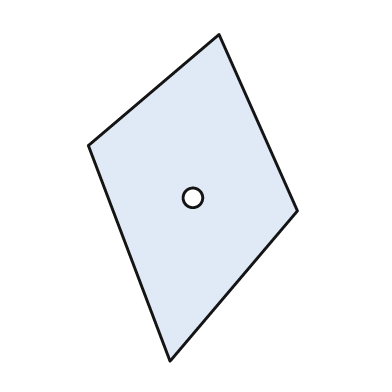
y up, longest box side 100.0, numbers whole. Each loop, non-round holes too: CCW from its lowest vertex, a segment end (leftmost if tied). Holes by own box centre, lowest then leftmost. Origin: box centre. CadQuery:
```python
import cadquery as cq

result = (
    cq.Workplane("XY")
    .moveTo(-7.0, -50.0)
    .lineTo(32.0, -4.0)
    .lineTo(8.0, 50.0)
    .lineTo(-32.0, 16.0)
    .close()
    .moveTo(0.0, 0.0)
    .circle(3.0)
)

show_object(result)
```